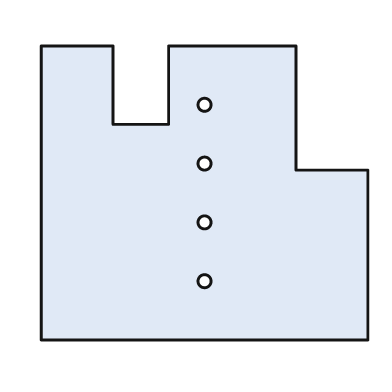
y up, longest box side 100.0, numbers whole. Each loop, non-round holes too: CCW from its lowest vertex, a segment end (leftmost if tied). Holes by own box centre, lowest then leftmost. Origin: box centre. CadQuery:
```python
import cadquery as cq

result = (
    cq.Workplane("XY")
    .moveTo(-50.0, -45.0)
    .lineTo(50.0, -45.0)
    .lineTo(50.0, 7.0)
    .lineTo(28.0, 7.0)
    .lineTo(28.0, 45.0)
    .lineTo(-11.0, 45.0)
    .lineTo(-11.0, 21.0)
    .lineTo(-28.0, 21.0)
    .lineTo(-28.0, 45.0)
    .lineTo(-50.0, 45.0)
    .close()
    .moveTo(0.0, -27.0)
    .circle(2.0)
    .moveTo(0.0, -9.0)
    .circle(2.0)
    .moveTo(0.0, 9.0)
    .circle(2.0)
    .moveTo(0.0, 27.0)
    .circle(2.0)
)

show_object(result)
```